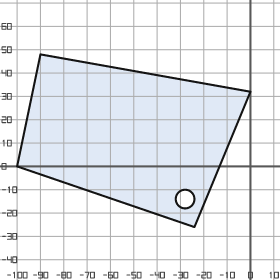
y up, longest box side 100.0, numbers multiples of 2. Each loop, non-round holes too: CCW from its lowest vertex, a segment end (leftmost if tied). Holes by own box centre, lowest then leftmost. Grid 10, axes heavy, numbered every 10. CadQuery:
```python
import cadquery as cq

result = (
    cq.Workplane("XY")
    .moveTo(-24.0, -26.0)
    .lineTo(0.0, 32.0)
    .lineTo(-90.0, 48.0)
    .lineTo(-100.0, 0.0)
    .close()
    .moveTo(-28.0, -14.0)
    .circle(4.0)
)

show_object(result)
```